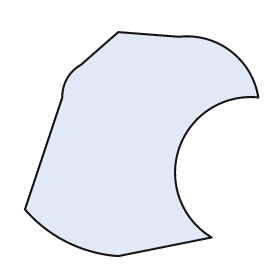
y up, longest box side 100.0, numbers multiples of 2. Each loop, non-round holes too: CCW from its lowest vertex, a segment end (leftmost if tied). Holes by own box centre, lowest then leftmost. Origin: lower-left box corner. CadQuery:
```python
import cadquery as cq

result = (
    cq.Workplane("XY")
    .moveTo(40.0, 0.0)
    .lineTo(80.0, 8.0)
    .threePointArc((66.0, 46.0), (100.0, 68.0))
    .threePointArc((88.0, 88.0), (66.0, 94.0))
    .lineTo(40.0, 96.0)
    .lineTo(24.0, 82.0)
    .threePointArc((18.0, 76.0), (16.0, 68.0))
    .lineTo(0.0, 20.0)
    .threePointArc((18.0, 6.0), (40.0, 0.0))
    .close()
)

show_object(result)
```